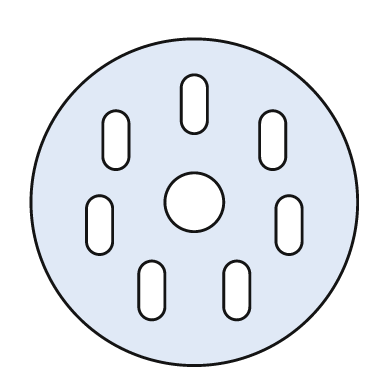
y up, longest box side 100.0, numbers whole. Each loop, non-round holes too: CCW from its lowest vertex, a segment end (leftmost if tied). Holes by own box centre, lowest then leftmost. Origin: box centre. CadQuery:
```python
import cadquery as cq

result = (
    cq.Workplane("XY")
    .moveTo(0.0, 0.0)
    .circle(50.0)
    .moveTo(-17.0, -32.0)
    .threePointArc((-13.0, -36.0), (-9.0, -32.0))
    .lineTo(-9.0, -22.0)
    .threePointArc((-13.0, -18.0), (-17.0, -22.0))
    .close()
    .moveTo(9.0, -32.0)
    .threePointArc((13.0, -36.0), (17.0, -32.0))
    .lineTo(17.0, -22.0)
    .threePointArc((13.0, -18.0), (9.0, -22.0))
    .close()
    .moveTo(-33.0, -12.0)
    .threePointArc((-29.0, -16.0), (-25.0, -12.0))
    .lineTo(-25.0, -2.0)
    .threePointArc((-29.0, 2.0), (-33.0, -2.0))
    .close()
    .moveTo(25.0, -12.0)
    .threePointArc((29.0, -16.0), (33.0, -12.0))
    .lineTo(33.0, -2.0)
    .threePointArc((29.0, 2.0), (25.0, -2.0))
    .close()
    .moveTo(0.0, 0.0)
    .circle(9.0)
    .moveTo(-28.0, 14.0)
    .threePointArc((-24.0, 10.0), (-20.0, 14.0))
    .lineTo(-20.0, 24.0)
    .threePointArc((-24.0, 28.0), (-28.0, 24.0))
    .close()
    .moveTo(20.0, 14.0)
    .threePointArc((24.0, 10.0), (28.0, 14.0))
    .lineTo(28.0, 24.0)
    .threePointArc((24.0, 28.0), (20.0, 24.0))
    .close()
    .moveTo(-4.0, 25.0)
    .threePointArc((0.0, 21.0), (4.0, 25.0))
    .lineTo(4.0, 35.0)
    .threePointArc((0.0, 39.0), (-4.0, 35.0))
    .close()
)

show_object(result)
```